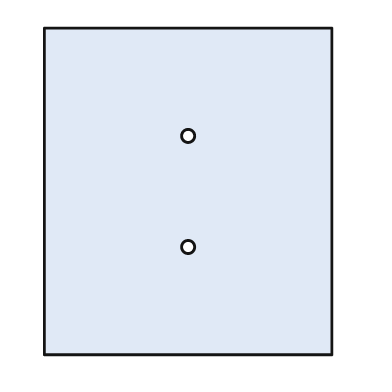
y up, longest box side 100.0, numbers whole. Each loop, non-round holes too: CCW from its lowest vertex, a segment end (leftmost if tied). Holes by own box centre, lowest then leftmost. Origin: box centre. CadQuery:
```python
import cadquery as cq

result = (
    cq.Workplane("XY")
    .moveTo(-44.0, -50.0)
    .lineTo(44.0, -50.0)
    .lineTo(44.0, 50.0)
    .lineTo(-44.0, 50.0)
    .close()
    .moveTo(0.0, -17.0)
    .circle(2.0)
    .moveTo(0.0, 17.0)
    .circle(2.0)
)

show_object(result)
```